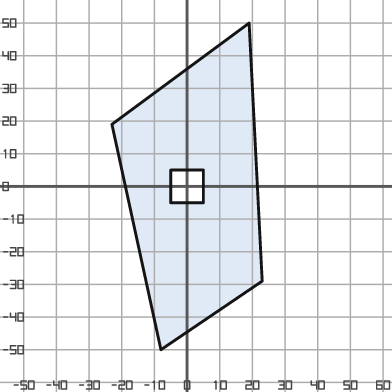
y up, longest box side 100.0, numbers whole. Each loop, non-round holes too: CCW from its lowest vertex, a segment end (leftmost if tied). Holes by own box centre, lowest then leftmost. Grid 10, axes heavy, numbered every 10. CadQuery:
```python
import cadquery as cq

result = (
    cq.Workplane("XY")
    .moveTo(-8.0, -50.0)
    .lineTo(23.0, -29.0)
    .lineTo(19.0, 50.0)
    .lineTo(-23.0, 19.0)
    .close()
    .moveTo(-5.0, -5.0)
    .lineTo(5.0, -5.0)
    .lineTo(5.0, 5.0)
    .lineTo(-5.0, 5.0)
    .close()
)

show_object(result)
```